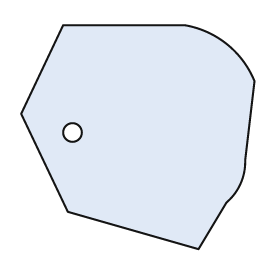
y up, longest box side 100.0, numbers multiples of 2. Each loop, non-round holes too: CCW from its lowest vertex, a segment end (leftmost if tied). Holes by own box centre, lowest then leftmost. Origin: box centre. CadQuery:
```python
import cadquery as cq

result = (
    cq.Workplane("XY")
    .moveTo(26.0, -48.0)
    .lineTo(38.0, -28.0)
    .threePointArc((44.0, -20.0), (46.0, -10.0))
    .lineTo(50.0, 24.0)
    .threePointArc((38.0, 40.0), (20.0, 48.0))
    .lineTo(-32.0, 48.0)
    .lineTo(-50.0, 10.0)
    .lineTo(-30.0, -32.0)
    .close()
    .moveTo(-28.0, 2.0)
    .circle(4.0)
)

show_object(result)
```